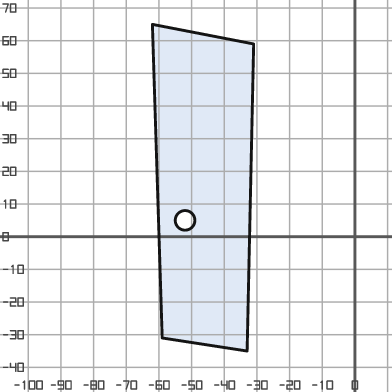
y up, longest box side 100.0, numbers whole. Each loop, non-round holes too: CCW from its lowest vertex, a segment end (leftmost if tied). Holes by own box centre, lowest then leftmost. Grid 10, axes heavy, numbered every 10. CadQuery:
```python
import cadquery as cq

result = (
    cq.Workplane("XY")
    .moveTo(-33.0, -35.0)
    .lineTo(-31.0, 59.0)
    .lineTo(-62.0, 65.0)
    .lineTo(-59.0, -31.0)
    .close()
    .moveTo(-52.0, 5.0)
    .circle(3.0)
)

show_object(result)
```